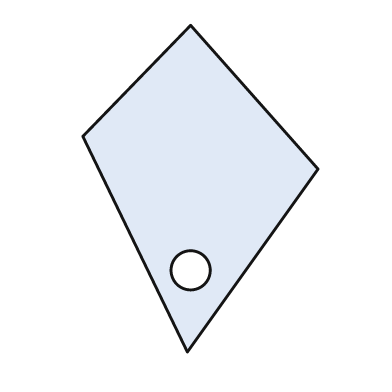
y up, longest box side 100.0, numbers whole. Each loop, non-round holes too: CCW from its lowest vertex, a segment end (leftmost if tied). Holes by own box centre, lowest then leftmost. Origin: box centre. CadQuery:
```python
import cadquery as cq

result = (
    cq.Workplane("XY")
    .moveTo(-4.0, -50.0)
    .lineTo(36.0, 6.0)
    .lineTo(-3.0, 50.0)
    .lineTo(-36.0, 16.0)
    .close()
    .moveTo(-3.0, -25.0)
    .circle(6.0)
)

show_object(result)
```